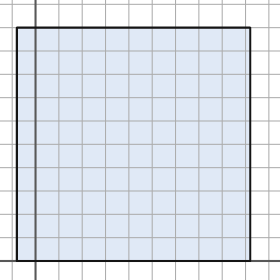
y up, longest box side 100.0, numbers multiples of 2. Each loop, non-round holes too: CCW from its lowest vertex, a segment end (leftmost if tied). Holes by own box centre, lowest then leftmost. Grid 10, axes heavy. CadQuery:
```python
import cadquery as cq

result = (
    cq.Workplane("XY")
    .moveTo(-8.0, 0.0)
    .lineTo(92.0, 0.0)
    .lineTo(92.0, 100.0)
    .lineTo(-8.0, 100.0)
    .close()
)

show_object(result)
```